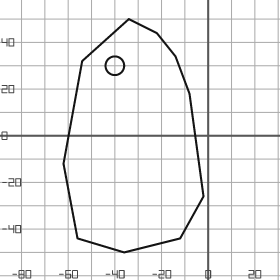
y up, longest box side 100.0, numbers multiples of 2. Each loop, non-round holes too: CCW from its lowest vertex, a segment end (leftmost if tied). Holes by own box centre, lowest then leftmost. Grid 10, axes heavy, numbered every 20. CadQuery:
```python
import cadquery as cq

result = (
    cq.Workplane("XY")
    .moveTo(-36.0, -50.0)
    .lineTo(-12.0, -44.0)
    .lineTo(-2.0, -26.0)
    .lineTo(-8.0, 18.0)
    .lineTo(-14.0, 34.0)
    .lineTo(-22.0, 44.0)
    .lineTo(-34.0, 50.0)
    .lineTo(-54.0, 32.0)
    .lineTo(-62.0, -12.0)
    .lineTo(-56.0, -44.0)
    .close()
    .moveTo(-40.0, 30.0)
    .circle(4.0)
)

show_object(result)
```